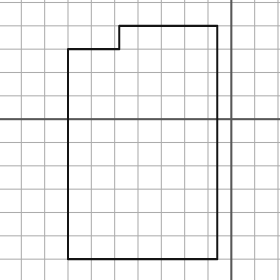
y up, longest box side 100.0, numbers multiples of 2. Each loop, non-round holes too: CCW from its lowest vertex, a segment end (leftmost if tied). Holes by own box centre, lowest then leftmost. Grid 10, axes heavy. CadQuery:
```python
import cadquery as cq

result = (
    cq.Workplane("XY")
    .moveTo(-70.0, -60.0)
    .lineTo(-6.0, -60.0)
    .lineTo(-6.0, 40.0)
    .lineTo(-48.0, 40.0)
    .lineTo(-48.0, 30.0)
    .lineTo(-70.0, 30.0)
    .close()
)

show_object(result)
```